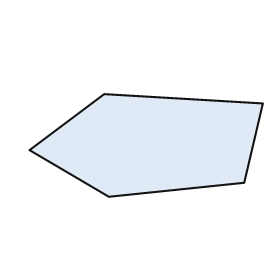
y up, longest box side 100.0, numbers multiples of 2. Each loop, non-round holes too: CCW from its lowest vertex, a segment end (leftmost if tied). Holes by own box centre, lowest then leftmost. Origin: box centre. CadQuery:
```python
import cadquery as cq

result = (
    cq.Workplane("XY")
    .moveTo(-16.0, -22.0)
    .lineTo(42.0, -16.0)
    .lineTo(50.0, 18.0)
    .lineTo(-18.0, 22.0)
    .lineTo(-50.0, -2.0)
    .close()
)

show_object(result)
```